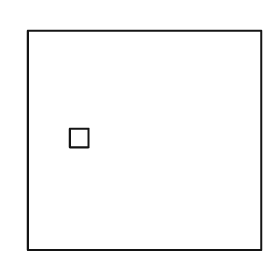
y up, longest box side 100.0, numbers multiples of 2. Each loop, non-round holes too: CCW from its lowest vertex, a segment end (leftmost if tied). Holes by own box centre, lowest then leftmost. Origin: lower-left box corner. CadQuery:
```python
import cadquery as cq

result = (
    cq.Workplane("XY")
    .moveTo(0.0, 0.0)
    .lineTo(100.0, 0.0)
    .lineTo(100.0, 94.0)
    .lineTo(0.0, 94.0)
    .close()
    .moveTo(18.0, 44.0)
    .lineTo(26.0, 44.0)
    .lineTo(26.0, 52.0)
    .lineTo(18.0, 52.0)
    .close()
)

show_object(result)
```